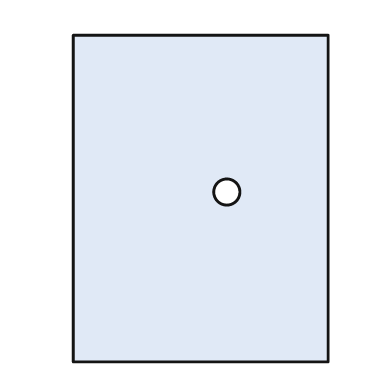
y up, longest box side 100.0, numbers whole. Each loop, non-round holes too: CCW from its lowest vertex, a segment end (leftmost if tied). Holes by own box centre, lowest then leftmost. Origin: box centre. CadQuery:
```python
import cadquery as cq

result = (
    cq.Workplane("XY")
    .moveTo(-39.0, -50.0)
    .lineTo(39.0, -50.0)
    .lineTo(39.0, 50.0)
    .lineTo(-39.0, 50.0)
    .close()
    .moveTo(8.0, 2.0)
    .circle(4.0)
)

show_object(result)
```